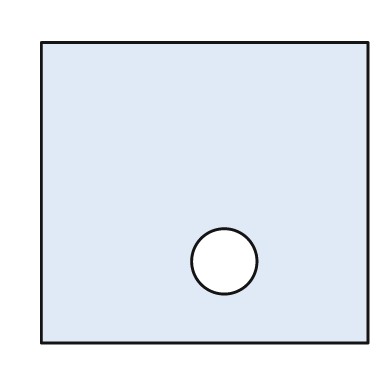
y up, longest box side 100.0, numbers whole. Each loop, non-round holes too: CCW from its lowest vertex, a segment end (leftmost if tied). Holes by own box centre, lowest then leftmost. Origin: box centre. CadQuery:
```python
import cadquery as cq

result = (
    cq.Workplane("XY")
    .moveTo(-50.0, -46.0)
    .lineTo(50.0, -46.0)
    .lineTo(50.0, 46.0)
    .lineTo(-50.0, 46.0)
    .close()
    .moveTo(6.0, -21.0)
    .circle(10.0)
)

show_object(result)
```